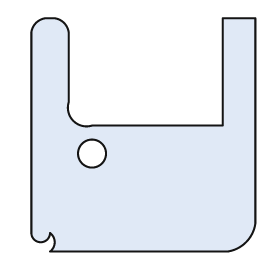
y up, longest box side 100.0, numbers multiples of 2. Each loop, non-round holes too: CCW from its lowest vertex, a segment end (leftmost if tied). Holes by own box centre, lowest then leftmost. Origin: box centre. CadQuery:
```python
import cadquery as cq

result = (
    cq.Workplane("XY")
    .moveTo(-40.0, -50.0)
    .lineTo(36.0, -50.0)
    .threePointArc((44.0, -46.0), (48.0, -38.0))
    .lineTo(48.0, 50.0)
    .lineTo(34.0, 50.0)
    .lineTo(34.0, 4.0)
    .lineTo(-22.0, 4.0)
    .threePointArc((-30.0, 6.0), (-32.0, 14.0))
    .lineTo(-32.0, 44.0)
    .threePointArc((-34.0, 48.0), (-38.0, 50.0))
    .lineTo(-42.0, 50.0)
    .threePointArc((-46.0, 48.0), (-48.0, 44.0))
    .lineTo(-48.0, -42.0)
    .threePointArc((-44.0, -46.0), (-40.0, -42.0))
    .threePointArc((-38.0, -46.0), (-40.0, -50.0))
    .close()
    .moveTo(-22.0, -8.0)
    .circle(6.0)
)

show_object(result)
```